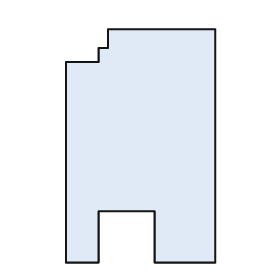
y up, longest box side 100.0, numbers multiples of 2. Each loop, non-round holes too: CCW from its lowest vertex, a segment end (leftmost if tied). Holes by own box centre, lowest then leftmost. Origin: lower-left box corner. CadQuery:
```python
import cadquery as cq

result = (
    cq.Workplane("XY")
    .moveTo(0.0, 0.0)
    .lineTo(14.0, 0.0)
    .lineTo(14.0, 22.0)
    .lineTo(38.0, 22.0)
    .lineTo(38.0, 0.0)
    .lineTo(64.0, 0.0)
    .lineTo(64.0, 100.0)
    .lineTo(18.0, 100.0)
    .lineTo(18.0, 92.0)
    .lineTo(14.0, 92.0)
    .lineTo(14.0, 86.0)
    .lineTo(0.0, 86.0)
    .close()
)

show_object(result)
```